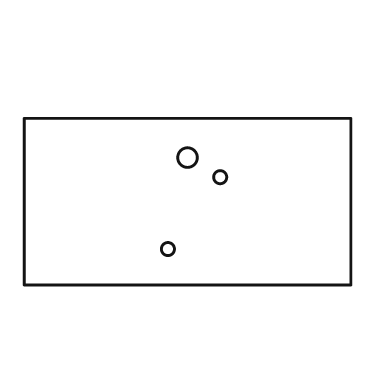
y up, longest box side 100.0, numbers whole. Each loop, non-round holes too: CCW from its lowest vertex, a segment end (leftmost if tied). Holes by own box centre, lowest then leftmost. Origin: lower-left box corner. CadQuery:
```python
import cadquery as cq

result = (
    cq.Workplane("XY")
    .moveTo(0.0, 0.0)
    .lineTo(100.0, 0.0)
    .lineTo(100.0, 51.0)
    .lineTo(0.0, 51.0)
    .close()
    .moveTo(44.0, 11.0)
    .circle(2.0)
    .moveTo(60.0, 33.0)
    .circle(2.0)
    .moveTo(50.0, 39.0)
    .circle(3.0)
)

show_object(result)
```